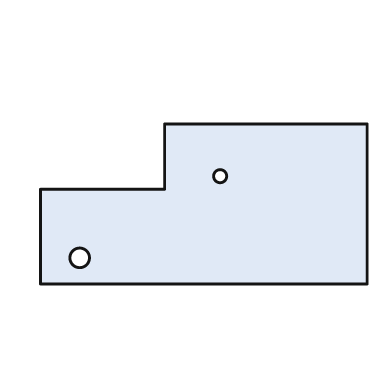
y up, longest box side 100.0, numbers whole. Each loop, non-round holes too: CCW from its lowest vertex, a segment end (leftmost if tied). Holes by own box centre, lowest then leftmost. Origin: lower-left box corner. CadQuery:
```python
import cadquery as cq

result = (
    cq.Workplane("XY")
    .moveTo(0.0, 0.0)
    .lineTo(100.0, 0.0)
    .lineTo(100.0, 49.0)
    .lineTo(38.0, 49.0)
    .lineTo(38.0, 29.0)
    .lineTo(0.0, 29.0)
    .close()
    .moveTo(12.0, 8.0)
    .circle(3.0)
    .moveTo(55.0, 33.0)
    .circle(2.0)
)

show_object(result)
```